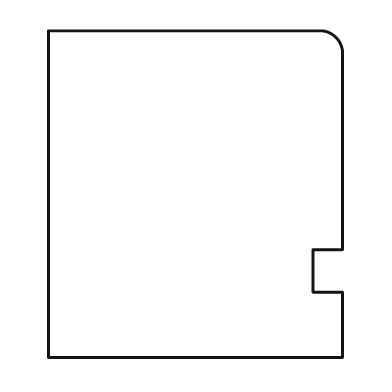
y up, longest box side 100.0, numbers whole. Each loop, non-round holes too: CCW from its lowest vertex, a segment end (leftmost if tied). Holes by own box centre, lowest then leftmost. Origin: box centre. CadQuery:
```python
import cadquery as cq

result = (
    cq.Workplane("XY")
    .moveTo(-45.0, -50.0)
    .lineTo(45.0, -50.0)
    .lineTo(45.0, -30.0)
    .lineTo(36.0, -30.0)
    .lineTo(36.0, -17.0)
    .lineTo(45.0, -17.0)
    .lineTo(45.0, 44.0)
    .threePointArc((43.0, 48.0), (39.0, 50.0))
    .lineTo(-45.0, 50.0)
    .close()
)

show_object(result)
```